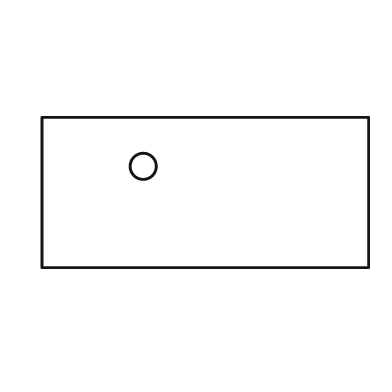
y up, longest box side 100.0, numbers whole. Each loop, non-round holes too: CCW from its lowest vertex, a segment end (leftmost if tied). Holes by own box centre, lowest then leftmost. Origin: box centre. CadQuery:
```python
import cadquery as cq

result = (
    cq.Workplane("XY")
    .moveTo(-50.0, -23.0)
    .lineTo(50.0, -23.0)
    .lineTo(50.0, 23.0)
    .lineTo(-50.0, 23.0)
    .close()
    .moveTo(-19.0, 8.0)
    .circle(4.0)
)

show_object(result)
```